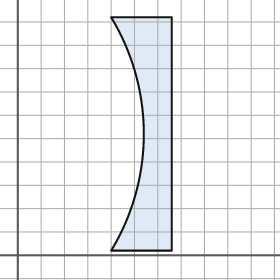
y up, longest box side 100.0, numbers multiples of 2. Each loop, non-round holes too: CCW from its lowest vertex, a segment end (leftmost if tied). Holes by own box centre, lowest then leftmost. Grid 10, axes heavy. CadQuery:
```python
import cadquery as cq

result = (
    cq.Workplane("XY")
    .moveTo(40.0, 2.0)
    .lineTo(66.0, 2.0)
    .lineTo(66.0, 102.0)
    .lineTo(40.0, 102.0)
    .threePointArc((54.0, 52.0), (40.0, 2.0))
    .close()
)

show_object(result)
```